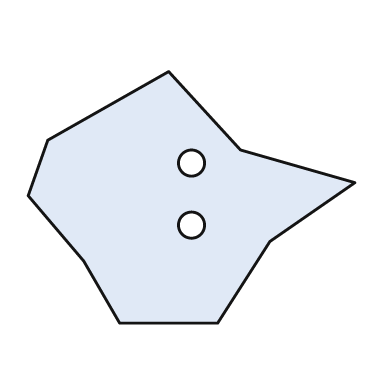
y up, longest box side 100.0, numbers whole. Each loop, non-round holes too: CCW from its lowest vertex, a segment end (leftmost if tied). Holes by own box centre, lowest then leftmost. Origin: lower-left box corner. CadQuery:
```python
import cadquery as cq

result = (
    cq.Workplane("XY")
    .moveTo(28.0, 0.0)
    .lineTo(58.0, 0.0)
    .lineTo(74.0, 25.0)
    .lineTo(100.0, 43.0)
    .lineTo(65.0, 53.0)
    .lineTo(43.0, 77.0)
    .lineTo(6.0, 56.0)
    .lineTo(0.0, 39.0)
    .lineTo(17.0, 19.0)
    .close()
    .moveTo(50.0, 30.0)
    .circle(4.0)
    .moveTo(50.0, 49.0)
    .circle(4.0)
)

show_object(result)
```